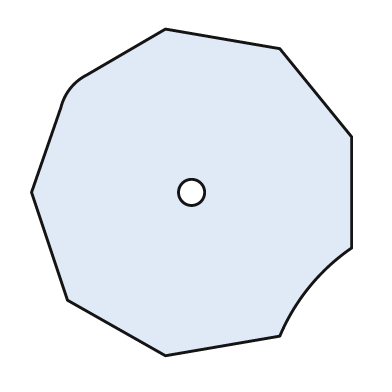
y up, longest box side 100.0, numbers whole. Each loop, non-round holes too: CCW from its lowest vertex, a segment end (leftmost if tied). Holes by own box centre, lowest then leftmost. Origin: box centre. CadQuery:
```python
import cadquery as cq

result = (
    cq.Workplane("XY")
    .moveTo(-8.0, -50.0)
    .lineTo(27.0, -44.0)
    .threePointArc((36.0, -29.0), (49.0, -17.0))
    .lineTo(49.0, 17.0)
    .lineTo(27.0, 44.0)
    .lineTo(-8.0, 50.0)
    .lineTo(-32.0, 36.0)
    .threePointArc((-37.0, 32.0), (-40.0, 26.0))
    .lineTo(-49.0, 0.0)
    .lineTo(-38.0, -33.0)
    .close()
    .moveTo(0.0, 0.0)
    .circle(4.0)
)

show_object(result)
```